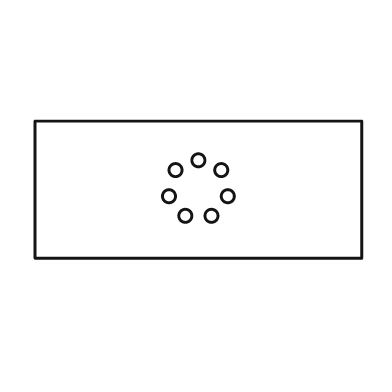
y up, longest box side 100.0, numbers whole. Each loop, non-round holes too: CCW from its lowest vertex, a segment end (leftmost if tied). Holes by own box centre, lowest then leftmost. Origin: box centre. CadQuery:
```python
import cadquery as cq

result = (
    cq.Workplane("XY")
    .moveTo(-50.0, -21.0)
    .lineTo(50.0, -21.0)
    .lineTo(50.0, 21.0)
    .lineTo(-50.0, 21.0)
    .close()
    .moveTo(-4.0, -8.0)
    .circle(2.0)
    .moveTo(4.0, -8.0)
    .circle(2.0)
    .moveTo(-9.0, -2.0)
    .circle(2.0)
    .moveTo(9.0, -2.0)
    .circle(2.0)
    .moveTo(-7.0, 6.0)
    .circle(2.0)
    .moveTo(7.0, 6.0)
    .circle(2.0)
    .moveTo(0.0, 9.0)
    .circle(2.0)
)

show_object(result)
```